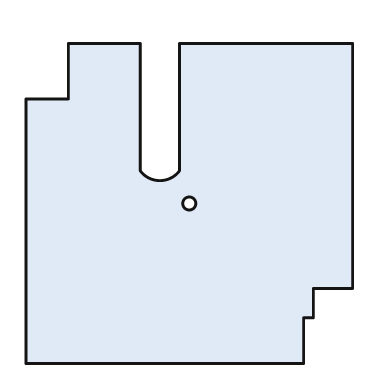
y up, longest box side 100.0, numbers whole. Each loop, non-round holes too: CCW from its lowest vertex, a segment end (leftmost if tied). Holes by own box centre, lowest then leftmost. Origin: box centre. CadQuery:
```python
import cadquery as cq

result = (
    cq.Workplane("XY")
    .moveTo(-50.0, -49.0)
    .lineTo(35.0, -49.0)
    .lineTo(35.0, -35.0)
    .lineTo(38.0, -35.0)
    .lineTo(38.0, -26.0)
    .lineTo(50.0, -26.0)
    .lineTo(50.0, 49.0)
    .lineTo(-3.0, 49.0)
    .lineTo(-3.0, 10.0)
    .threePointArc((-9.0, 7.0), (-15.0, 10.0))
    .lineTo(-15.0, 49.0)
    .lineTo(-37.0, 49.0)
    .lineTo(-37.0, 32.0)
    .lineTo(-50.0, 32.0)
    .close()
    .moveTo(0.0, 0.0)
    .circle(2.0)
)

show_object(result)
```